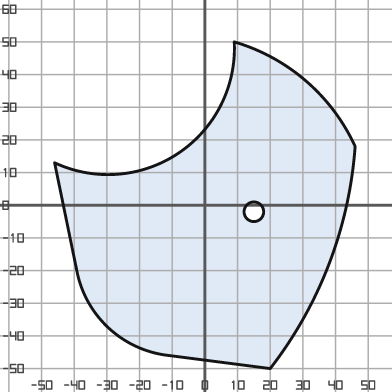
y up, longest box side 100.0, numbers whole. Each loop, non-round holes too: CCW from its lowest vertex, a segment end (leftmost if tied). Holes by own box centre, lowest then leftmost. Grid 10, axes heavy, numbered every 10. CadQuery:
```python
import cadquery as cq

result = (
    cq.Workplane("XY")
    .moveTo(20.0, -50.0)
    .threePointArc((38.0, -18.0), (46.0, 18.0))
    .threePointArc((31.0, 38.0), (9.0, 50.0))
    .threePointArc((-8.0, 16.0), (-46.0, 13.0))
    .lineTo(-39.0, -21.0)
    .threePointArc((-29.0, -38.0), (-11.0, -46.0))
    .close()
    .moveTo(15.0, -2.0)
    .circle(3.0)
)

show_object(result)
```